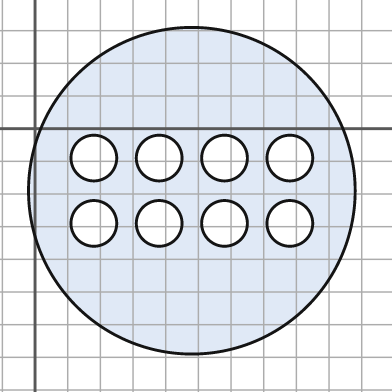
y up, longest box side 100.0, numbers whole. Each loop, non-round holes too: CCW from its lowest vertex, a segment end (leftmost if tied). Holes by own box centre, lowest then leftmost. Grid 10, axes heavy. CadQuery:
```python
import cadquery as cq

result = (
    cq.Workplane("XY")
    .moveTo(48.0, -19.0)
    .circle(50.0)
    .moveTo(18.0, -29.0)
    .circle(7.0)
    .moveTo(38.0, -29.0)
    .circle(7.0)
    .moveTo(58.0, -29.0)
    .circle(7.0)
    .moveTo(78.0, -29.0)
    .circle(7.0)
    .moveTo(18.0, -9.0)
    .circle(7.0)
    .moveTo(38.0, -9.0)
    .circle(7.0)
    .moveTo(58.0, -9.0)
    .circle(7.0)
    .moveTo(78.0, -9.0)
    .circle(7.0)
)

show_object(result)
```